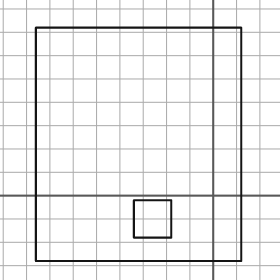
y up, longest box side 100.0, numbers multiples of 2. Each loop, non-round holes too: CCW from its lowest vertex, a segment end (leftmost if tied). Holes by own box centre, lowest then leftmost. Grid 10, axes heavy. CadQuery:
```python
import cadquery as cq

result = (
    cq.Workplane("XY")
    .moveTo(-76.0, -28.0)
    .lineTo(12.0, -28.0)
    .lineTo(12.0, 72.0)
    .lineTo(-76.0, 72.0)
    .close()
    .moveTo(-34.0, -18.0)
    .lineTo(-18.0, -18.0)
    .lineTo(-18.0, -2.0)
    .lineTo(-34.0, -2.0)
    .close()
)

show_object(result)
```